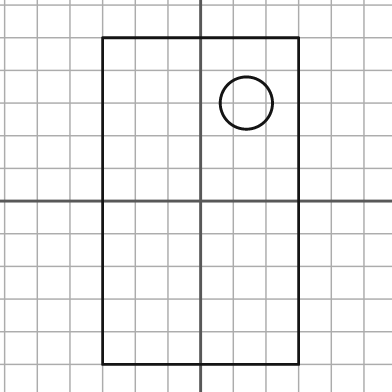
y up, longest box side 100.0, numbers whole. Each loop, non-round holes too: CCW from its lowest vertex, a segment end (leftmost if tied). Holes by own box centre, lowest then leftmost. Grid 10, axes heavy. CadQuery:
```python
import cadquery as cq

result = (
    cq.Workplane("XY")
    .moveTo(-30.0, -50.0)
    .lineTo(30.0, -50.0)
    .lineTo(30.0, 50.0)
    .lineTo(-30.0, 50.0)
    .close()
    .moveTo(14.0, 30.0)
    .circle(8.0)
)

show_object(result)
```